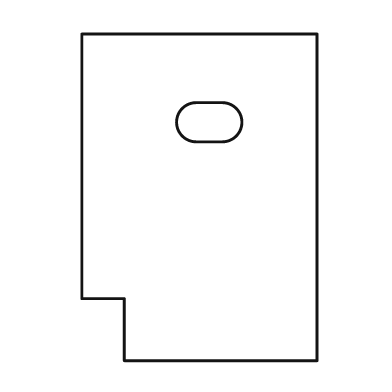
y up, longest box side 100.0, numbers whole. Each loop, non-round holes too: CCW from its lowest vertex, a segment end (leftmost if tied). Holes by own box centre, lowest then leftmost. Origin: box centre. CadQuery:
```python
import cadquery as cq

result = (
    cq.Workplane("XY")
    .moveTo(-23.0, -50.0)
    .lineTo(36.0, -50.0)
    .lineTo(36.0, 50.0)
    .lineTo(-36.0, 50.0)
    .lineTo(-36.0, -31.0)
    .lineTo(-23.0, -31.0)
    .close()
    .moveTo(-1.0, 17.0)
    .lineTo(7.0, 17.0)
    .threePointArc((13.0, 23.0), (7.0, 29.0))
    .lineTo(-1.0, 29.0)
    .threePointArc((-7.0, 23.0), (-1.0, 17.0))
    .close()
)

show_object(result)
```